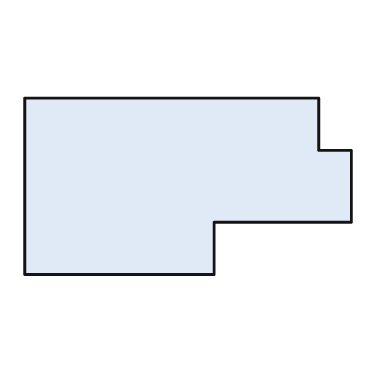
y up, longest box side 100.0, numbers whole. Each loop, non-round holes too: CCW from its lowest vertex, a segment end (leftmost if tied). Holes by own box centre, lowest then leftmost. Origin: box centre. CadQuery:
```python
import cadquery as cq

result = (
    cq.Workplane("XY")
    .moveTo(-50.0, -27.0)
    .lineTo(8.0, -27.0)
    .lineTo(8.0, -11.0)
    .lineTo(50.0, -11.0)
    .lineTo(50.0, 11.0)
    .lineTo(40.0, 11.0)
    .lineTo(40.0, 27.0)
    .lineTo(-50.0, 27.0)
    .close()
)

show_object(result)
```